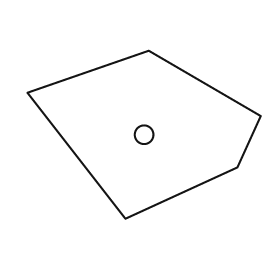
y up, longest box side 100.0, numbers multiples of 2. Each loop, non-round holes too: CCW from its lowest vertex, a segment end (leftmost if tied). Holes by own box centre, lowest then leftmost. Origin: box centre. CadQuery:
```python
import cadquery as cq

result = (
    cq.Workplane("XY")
    .moveTo(-8.0, -36.0)
    .lineTo(40.0, -14.0)
    .lineTo(50.0, 8.0)
    .lineTo(2.0, 36.0)
    .lineTo(-50.0, 18.0)
    .close()
    .moveTo(0.0, 0.0)
    .circle(4.0)
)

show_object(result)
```